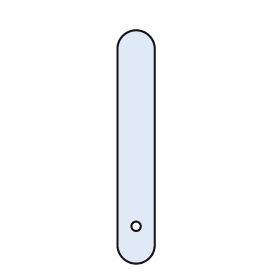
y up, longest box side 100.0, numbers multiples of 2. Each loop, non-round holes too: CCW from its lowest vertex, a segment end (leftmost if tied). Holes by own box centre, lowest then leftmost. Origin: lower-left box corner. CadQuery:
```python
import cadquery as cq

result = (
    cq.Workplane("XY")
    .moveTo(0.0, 8.0)
    .threePointArc((8.0, 0.0), (16.0, 8.0))
    .lineTo(16.0, 92.0)
    .threePointArc((8.0, 100.0), (0.0, 92.0))
    .close()
    .moveTo(8.0, 16.0)
    .circle(2.0)
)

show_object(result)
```